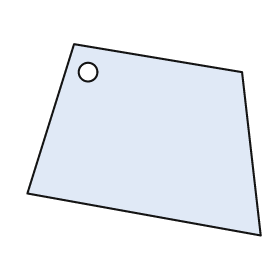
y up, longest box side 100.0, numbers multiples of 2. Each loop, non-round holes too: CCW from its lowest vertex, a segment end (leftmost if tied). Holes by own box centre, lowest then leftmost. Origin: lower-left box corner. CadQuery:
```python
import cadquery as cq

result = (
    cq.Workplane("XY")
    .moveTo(100.0, 0.0)
    .lineTo(92.0, 70.0)
    .lineTo(20.0, 82.0)
    .lineTo(0.0, 18.0)
    .close()
    .moveTo(26.0, 70.0)
    .circle(4.0)
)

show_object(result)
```